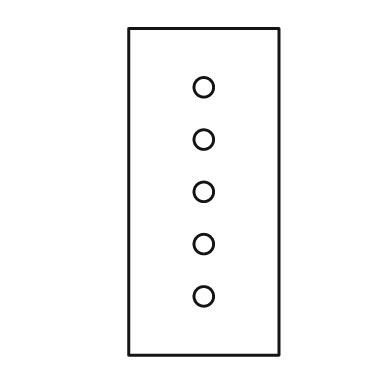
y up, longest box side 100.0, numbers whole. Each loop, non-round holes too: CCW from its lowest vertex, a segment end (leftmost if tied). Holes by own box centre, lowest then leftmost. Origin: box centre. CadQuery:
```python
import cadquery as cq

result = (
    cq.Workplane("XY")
    .moveTo(-23.0, -50.0)
    .lineTo(23.0, -50.0)
    .lineTo(23.0, 50.0)
    .lineTo(-23.0, 50.0)
    .close()
    .moveTo(0.0, -32.0)
    .circle(3.0)
    .moveTo(0.0, -16.0)
    .circle(3.0)
    .moveTo(0.0, 0.0)
    .circle(3.0)
    .moveTo(0.0, 16.0)
    .circle(3.0)
    .moveTo(0.0, 32.0)
    .circle(3.0)
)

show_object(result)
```